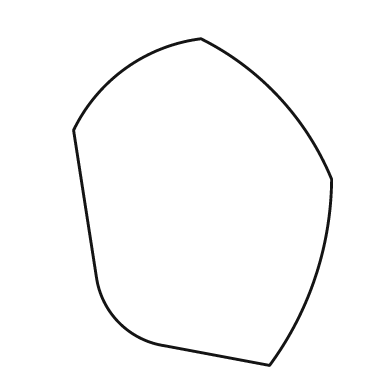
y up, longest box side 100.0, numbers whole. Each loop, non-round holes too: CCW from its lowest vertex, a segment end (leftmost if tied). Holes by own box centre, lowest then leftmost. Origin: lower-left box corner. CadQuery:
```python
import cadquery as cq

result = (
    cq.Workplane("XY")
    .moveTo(60.0, 0.0)
    .threePointArc((74.0, 27.0), (79.0, 57.0))
    .threePointArc((63.0, 82.0), (39.0, 100.0))
    .threePointArc((16.0, 91.0), (0.0, 72.0))
    .lineTo(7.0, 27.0)
    .threePointArc((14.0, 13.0), (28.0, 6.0))
    .close()
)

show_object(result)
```